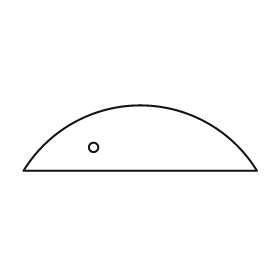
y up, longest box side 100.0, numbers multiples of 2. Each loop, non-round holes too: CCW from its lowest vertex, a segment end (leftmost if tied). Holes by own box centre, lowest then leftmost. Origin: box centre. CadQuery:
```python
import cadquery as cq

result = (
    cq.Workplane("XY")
    .moveTo(-50.0, -14.0)
    .lineTo(50.0, -14.0)
    .threePointArc((0.0, 14.0), (-50.0, -14.0))
    .close()
    .moveTo(-20.0, -4.0)
    .circle(2.0)
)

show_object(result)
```